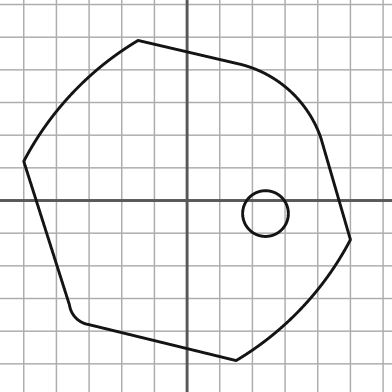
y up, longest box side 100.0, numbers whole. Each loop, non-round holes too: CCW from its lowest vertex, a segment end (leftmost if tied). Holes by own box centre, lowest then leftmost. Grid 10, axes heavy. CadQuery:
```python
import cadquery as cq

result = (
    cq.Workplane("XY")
    .moveTo(15.0, -49.0)
    .threePointArc((35.0, -33.0), (50.0, -12.0))
    .lineTo(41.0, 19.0)
    .threePointArc((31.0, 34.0), (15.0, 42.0))
    .lineTo(-15.0, 49.0)
    .threePointArc((-35.0, 33.0), (-50.0, 12.0))
    .lineTo(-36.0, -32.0)
    .threePointArc((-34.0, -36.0), (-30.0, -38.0))
    .close()
    .moveTo(24.0, -4.0)
    .circle(7.0)
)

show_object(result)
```